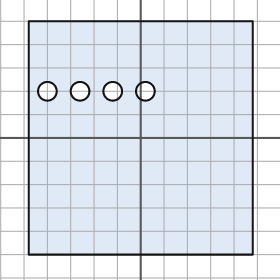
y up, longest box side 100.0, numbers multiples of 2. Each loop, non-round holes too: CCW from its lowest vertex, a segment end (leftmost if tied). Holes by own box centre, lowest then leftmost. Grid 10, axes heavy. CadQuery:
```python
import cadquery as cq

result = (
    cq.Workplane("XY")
    .moveTo(-48.0, -50.0)
    .lineTo(48.0, -50.0)
    .lineTo(48.0, 50.0)
    .lineTo(-48.0, 50.0)
    .close()
    .moveTo(-40.0, 20.0)
    .circle(4.0)
    .moveTo(-26.0, 20.0)
    .circle(4.0)
    .moveTo(-12.0, 20.0)
    .circle(4.0)
    .moveTo(2.0, 20.0)
    .circle(4.0)
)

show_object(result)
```